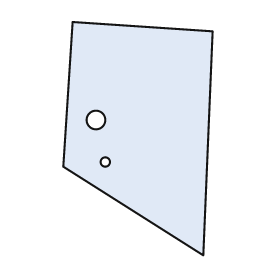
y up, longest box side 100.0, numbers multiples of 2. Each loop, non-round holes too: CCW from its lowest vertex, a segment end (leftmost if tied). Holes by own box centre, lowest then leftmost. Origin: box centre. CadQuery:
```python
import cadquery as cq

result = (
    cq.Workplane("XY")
    .moveTo(28.0, -50.0)
    .lineTo(32.0, 46.0)
    .lineTo(-28.0, 50.0)
    .lineTo(-32.0, -12.0)
    .close()
    .moveTo(-14.0, -10.0)
    .circle(2.0)
    .moveTo(-18.0, 8.0)
    .circle(4.0)
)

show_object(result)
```